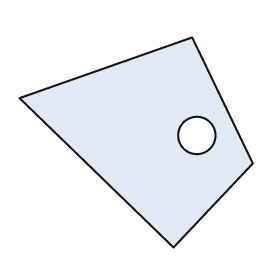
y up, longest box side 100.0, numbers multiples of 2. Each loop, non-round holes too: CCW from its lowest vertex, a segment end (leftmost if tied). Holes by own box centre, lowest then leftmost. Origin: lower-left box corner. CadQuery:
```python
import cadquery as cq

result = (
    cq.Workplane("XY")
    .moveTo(66.0, 0.0)
    .lineTo(100.0, 36.0)
    .lineTo(74.0, 90.0)
    .lineTo(0.0, 64.0)
    .close()
    .moveTo(76.0, 48.0)
    .circle(8.0)
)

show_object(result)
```